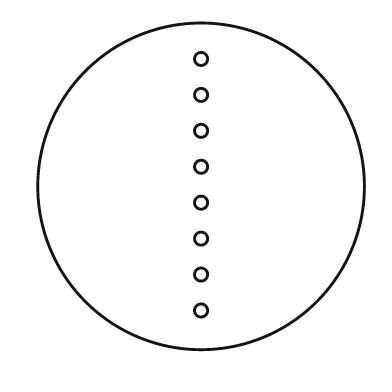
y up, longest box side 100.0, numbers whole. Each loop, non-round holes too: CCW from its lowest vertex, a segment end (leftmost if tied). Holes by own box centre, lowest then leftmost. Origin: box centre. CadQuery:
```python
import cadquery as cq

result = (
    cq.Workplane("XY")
    .moveTo(0.0, 0.0)
    .circle(50.0)
    .moveTo(0.0, -38.0)
    .circle(2.0)
    .moveTo(0.0, -27.0)
    .circle(2.0)
    .moveTo(0.0, -16.0)
    .circle(2.0)
    .moveTo(0.0, -5.0)
    .circle(2.0)
    .moveTo(0.0, 6.0)
    .circle(2.0)
    .moveTo(0.0, 17.0)
    .circle(2.0)
    .moveTo(0.0, 28.0)
    .circle(2.0)
    .moveTo(0.0, 39.0)
    .circle(2.0)
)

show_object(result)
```